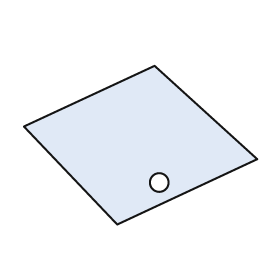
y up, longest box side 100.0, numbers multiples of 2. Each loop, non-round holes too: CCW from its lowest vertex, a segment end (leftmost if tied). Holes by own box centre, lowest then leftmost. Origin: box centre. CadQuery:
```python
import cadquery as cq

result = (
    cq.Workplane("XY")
    .moveTo(-10.0, -34.0)
    .lineTo(50.0, -6.0)
    .lineTo(6.0, 34.0)
    .lineTo(-50.0, 8.0)
    .close()
    .moveTo(8.0, -16.0)
    .circle(4.0)
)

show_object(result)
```